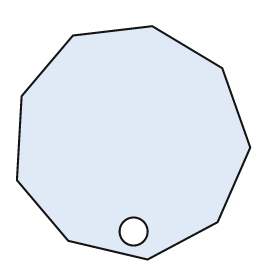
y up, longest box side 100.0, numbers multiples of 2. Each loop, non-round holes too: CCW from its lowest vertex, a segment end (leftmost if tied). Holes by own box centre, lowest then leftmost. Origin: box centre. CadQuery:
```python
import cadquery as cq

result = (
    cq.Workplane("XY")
    .moveTo(6.0, -50.0)
    .lineTo(36.0, -34.0)
    .lineTo(50.0, -2.0)
    .lineTo(38.0, 32.0)
    .lineTo(8.0, 50.0)
    .lineTo(-26.0, 46.0)
    .lineTo(-48.0, 20.0)
    .lineTo(-50.0, -16.0)
    .lineTo(-28.0, -42.0)
    .close()
    .moveTo(0.0, -38.0)
    .circle(6.0)
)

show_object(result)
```